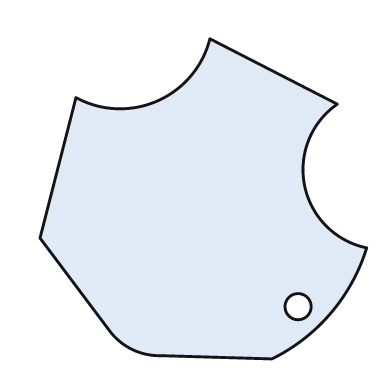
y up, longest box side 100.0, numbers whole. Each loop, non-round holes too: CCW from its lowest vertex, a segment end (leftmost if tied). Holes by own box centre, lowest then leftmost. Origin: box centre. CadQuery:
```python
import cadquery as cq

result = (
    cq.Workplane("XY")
    .moveTo(21.0, -49.0)
    .threePointArc((39.0, -35.0), (50.0, -15.0))
    .threePointArc((31.0, 4.0), (41.0, 29.0))
    .lineTo(2.0, 49.0)
    .threePointArc((-14.0, 30.0), (-39.0, 31.0))
    .lineTo(-50.0, -12.0)
    .lineTo(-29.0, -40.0)
    .threePointArc((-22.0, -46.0), (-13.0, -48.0))
    .close()
    .moveTo(29.0, -33.0)
    .circle(4.0)
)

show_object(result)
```